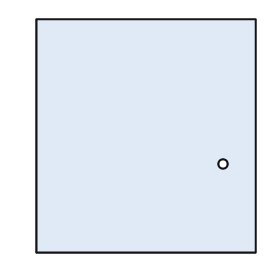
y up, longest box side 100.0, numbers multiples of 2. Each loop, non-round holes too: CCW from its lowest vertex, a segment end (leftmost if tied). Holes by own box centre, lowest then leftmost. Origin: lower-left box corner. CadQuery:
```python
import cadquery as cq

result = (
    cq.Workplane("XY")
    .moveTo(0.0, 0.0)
    .lineTo(94.0, 0.0)
    .lineTo(94.0, 100.0)
    .lineTo(0.0, 100.0)
    .close()
    .moveTo(80.0, 38.0)
    .circle(2.0)
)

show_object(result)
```